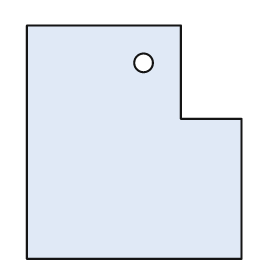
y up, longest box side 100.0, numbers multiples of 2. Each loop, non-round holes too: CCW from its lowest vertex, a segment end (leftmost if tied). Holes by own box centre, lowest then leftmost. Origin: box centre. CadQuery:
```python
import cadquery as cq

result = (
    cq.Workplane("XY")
    .moveTo(-46.0, -50.0)
    .lineTo(46.0, -50.0)
    .lineTo(46.0, 10.0)
    .lineTo(20.0, 10.0)
    .lineTo(20.0, 50.0)
    .lineTo(-46.0, 50.0)
    .close()
    .moveTo(4.0, 34.0)
    .circle(4.0)
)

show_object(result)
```